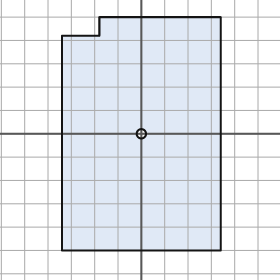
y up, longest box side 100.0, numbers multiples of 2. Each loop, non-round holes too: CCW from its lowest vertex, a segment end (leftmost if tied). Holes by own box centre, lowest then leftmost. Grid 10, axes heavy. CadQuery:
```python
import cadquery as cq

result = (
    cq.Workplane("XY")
    .moveTo(-34.0, -50.0)
    .lineTo(34.0, -50.0)
    .lineTo(34.0, 50.0)
    .lineTo(-18.0, 50.0)
    .lineTo(-18.0, 42.0)
    .lineTo(-34.0, 42.0)
    .close()
    .moveTo(0.0, 0.0)
    .circle(2.0)
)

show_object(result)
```